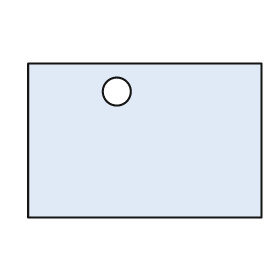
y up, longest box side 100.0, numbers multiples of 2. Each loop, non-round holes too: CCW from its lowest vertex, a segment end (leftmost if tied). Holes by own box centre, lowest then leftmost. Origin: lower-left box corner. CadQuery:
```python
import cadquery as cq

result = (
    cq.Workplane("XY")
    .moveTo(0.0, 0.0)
    .lineTo(100.0, 0.0)
    .lineTo(100.0, 66.0)
    .lineTo(0.0, 66.0)
    .close()
    .moveTo(38.0, 54.0)
    .circle(6.0)
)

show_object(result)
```